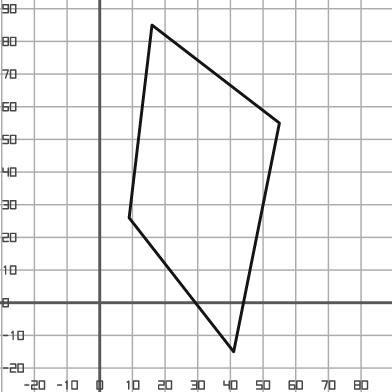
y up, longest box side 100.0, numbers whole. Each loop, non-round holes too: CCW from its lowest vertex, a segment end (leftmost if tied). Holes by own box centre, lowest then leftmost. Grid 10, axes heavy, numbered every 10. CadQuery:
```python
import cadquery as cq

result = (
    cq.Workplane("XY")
    .moveTo(41.0, -15.0)
    .lineTo(55.0, 55.0)
    .lineTo(16.0, 85.0)
    .lineTo(9.0, 26.0)
    .close()
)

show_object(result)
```